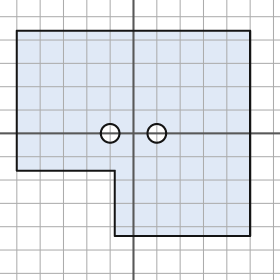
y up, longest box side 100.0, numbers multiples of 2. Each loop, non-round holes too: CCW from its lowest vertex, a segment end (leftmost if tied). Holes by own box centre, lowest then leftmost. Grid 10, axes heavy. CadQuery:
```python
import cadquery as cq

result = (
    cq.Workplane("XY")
    .moveTo(-8.0, -44.0)
    .lineTo(50.0, -44.0)
    .lineTo(50.0, 44.0)
    .lineTo(-50.0, 44.0)
    .lineTo(-50.0, -16.0)
    .lineTo(-8.0, -16.0)
    .close()
    .moveTo(-10.0, 0.0)
    .circle(4.0)
    .moveTo(10.0, 0.0)
    .circle(4.0)
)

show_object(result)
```